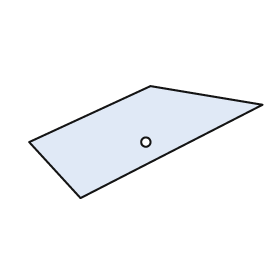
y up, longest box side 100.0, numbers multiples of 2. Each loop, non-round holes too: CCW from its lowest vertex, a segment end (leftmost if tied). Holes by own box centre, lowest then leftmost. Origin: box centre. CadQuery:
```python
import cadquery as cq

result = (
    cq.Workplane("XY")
    .moveTo(-28.0, -24.0)
    .lineTo(50.0, 16.0)
    .lineTo(2.0, 24.0)
    .lineTo(-50.0, 0.0)
    .close()
    .moveTo(0.0, 0.0)
    .circle(2.0)
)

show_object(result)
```